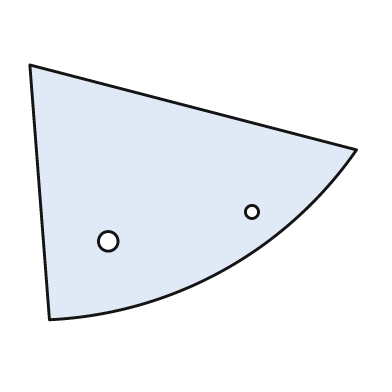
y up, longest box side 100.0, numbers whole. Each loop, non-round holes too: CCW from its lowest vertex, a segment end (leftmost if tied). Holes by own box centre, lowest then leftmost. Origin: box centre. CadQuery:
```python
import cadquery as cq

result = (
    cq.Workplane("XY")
    .moveTo(-44.0, -39.0)
    .threePointArc((9.0, -24.0), (50.0, 13.0))
    .lineTo(-50.0, 39.0)
    .close()
    .moveTo(-26.0, -15.0)
    .circle(3.0)
    .moveTo(18.0, -6.0)
    .circle(2.0)
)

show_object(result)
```